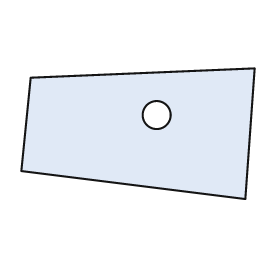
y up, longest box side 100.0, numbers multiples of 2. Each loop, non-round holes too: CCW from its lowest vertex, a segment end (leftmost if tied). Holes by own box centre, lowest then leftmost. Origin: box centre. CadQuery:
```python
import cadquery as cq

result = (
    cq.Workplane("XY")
    .moveTo(46.0, -28.0)
    .lineTo(50.0, 28.0)
    .lineTo(-46.0, 24.0)
    .lineTo(-50.0, -16.0)
    .close()
    .moveTo(8.0, 8.0)
    .circle(6.0)
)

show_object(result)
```